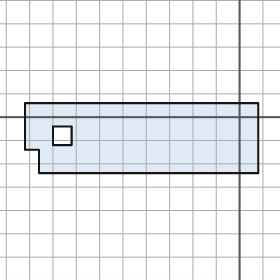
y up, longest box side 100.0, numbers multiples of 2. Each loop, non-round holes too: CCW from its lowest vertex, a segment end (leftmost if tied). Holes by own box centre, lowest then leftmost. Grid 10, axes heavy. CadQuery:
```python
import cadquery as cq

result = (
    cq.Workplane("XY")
    .moveTo(-86.0, -24.0)
    .lineTo(8.0, -24.0)
    .lineTo(8.0, 6.0)
    .lineTo(-92.0, 6.0)
    .lineTo(-92.0, -14.0)
    .lineTo(-86.0, -14.0)
    .close()
    .moveTo(-80.0, -12.0)
    .lineTo(-72.0, -12.0)
    .lineTo(-72.0, -4.0)
    .lineTo(-80.0, -4.0)
    .close()
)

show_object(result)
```